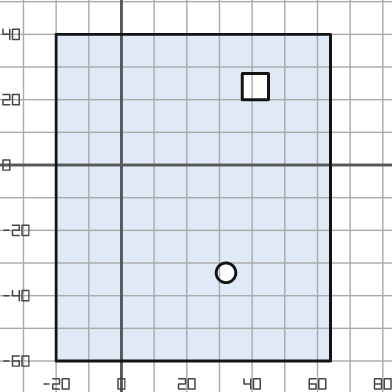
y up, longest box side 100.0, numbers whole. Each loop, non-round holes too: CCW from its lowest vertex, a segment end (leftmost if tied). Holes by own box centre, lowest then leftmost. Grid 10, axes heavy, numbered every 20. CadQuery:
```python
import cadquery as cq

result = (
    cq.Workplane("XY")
    .moveTo(-20.0, -60.0)
    .lineTo(64.0, -60.0)
    .lineTo(64.0, 40.0)
    .lineTo(-20.0, 40.0)
    .close()
    .moveTo(32.0, -33.0)
    .circle(3.0)
    .moveTo(37.0, 20.0)
    .lineTo(45.0, 20.0)
    .lineTo(45.0, 28.0)
    .lineTo(37.0, 28.0)
    .close()
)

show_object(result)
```